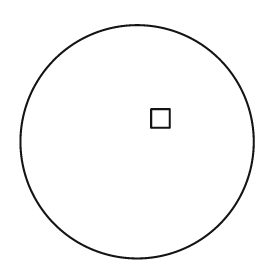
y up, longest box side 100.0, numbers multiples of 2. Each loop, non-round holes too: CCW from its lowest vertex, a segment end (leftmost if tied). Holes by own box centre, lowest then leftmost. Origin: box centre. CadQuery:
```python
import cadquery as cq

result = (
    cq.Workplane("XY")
    .moveTo(0.0, 0.0)
    .circle(50.0)
    .moveTo(6.0, 6.0)
    .lineTo(14.0, 6.0)
    .lineTo(14.0, 14.0)
    .lineTo(6.0, 14.0)
    .close()
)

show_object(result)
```